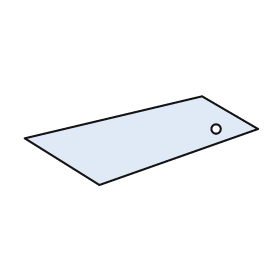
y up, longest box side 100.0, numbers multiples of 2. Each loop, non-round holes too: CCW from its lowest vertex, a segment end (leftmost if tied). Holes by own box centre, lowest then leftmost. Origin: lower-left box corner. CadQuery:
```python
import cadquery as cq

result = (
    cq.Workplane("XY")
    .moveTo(32.0, 0.0)
    .lineTo(100.0, 24.0)
    .lineTo(76.0, 38.0)
    .lineTo(0.0, 20.0)
    .close()
    .moveTo(82.0, 24.0)
    .circle(2.0)
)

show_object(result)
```